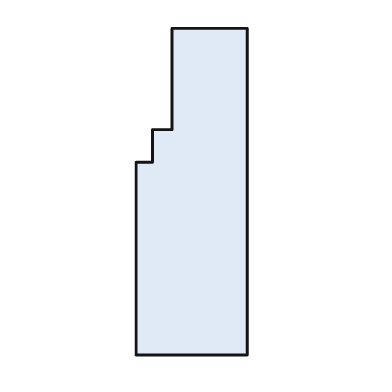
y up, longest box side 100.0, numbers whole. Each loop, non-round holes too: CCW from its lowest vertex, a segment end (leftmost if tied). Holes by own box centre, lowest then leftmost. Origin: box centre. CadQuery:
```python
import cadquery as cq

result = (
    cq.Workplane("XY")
    .moveTo(-17.0, -50.0)
    .lineTo(17.0, -50.0)
    .lineTo(17.0, 50.0)
    .lineTo(-6.0, 50.0)
    .lineTo(-6.0, 19.0)
    .lineTo(-12.0, 19.0)
    .lineTo(-12.0, 9.0)
    .lineTo(-17.0, 9.0)
    .close()
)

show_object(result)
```